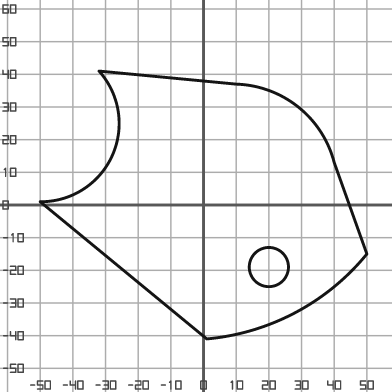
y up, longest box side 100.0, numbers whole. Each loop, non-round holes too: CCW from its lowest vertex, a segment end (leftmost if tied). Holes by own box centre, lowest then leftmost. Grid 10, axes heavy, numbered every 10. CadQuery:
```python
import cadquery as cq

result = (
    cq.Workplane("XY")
    .moveTo(1.0, -41.0)
    .threePointArc((28.0, -33.0), (50.0, -15.0))
    .lineTo(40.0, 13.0)
    .threePointArc((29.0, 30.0), (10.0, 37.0))
    .lineTo(-32.0, 41.0)
    .threePointArc((-28.0, 15.0), (-50.0, 1.0))
    .close()
    .moveTo(20.0, -19.0)
    .circle(6.0)
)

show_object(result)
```